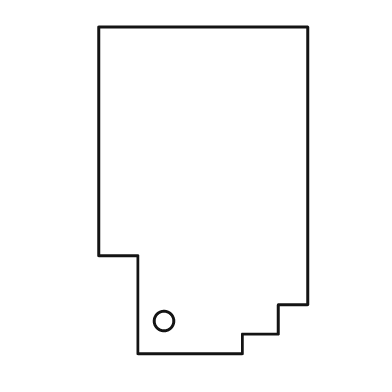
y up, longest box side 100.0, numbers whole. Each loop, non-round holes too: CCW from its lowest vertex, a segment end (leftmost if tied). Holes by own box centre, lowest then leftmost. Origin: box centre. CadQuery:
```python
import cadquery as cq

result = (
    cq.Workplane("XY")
    .moveTo(-20.0, -50.0)
    .lineTo(12.0, -50.0)
    .lineTo(12.0, -44.0)
    .lineTo(23.0, -44.0)
    .lineTo(23.0, -35.0)
    .lineTo(32.0, -35.0)
    .lineTo(32.0, 50.0)
    .lineTo(-32.0, 50.0)
    .lineTo(-32.0, -20.0)
    .lineTo(-20.0, -20.0)
    .close()
    .moveTo(-12.0, -40.0)
    .circle(3.0)
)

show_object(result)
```